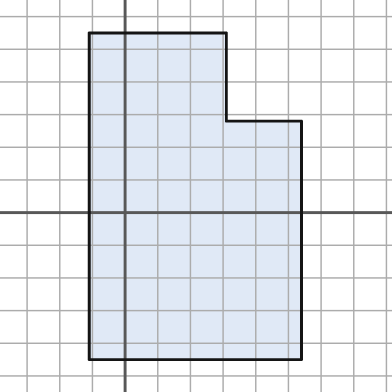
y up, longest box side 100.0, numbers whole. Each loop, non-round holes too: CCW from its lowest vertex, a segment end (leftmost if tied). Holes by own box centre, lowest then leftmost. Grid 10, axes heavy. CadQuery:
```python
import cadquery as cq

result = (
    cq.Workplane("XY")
    .moveTo(-11.0, -45.0)
    .lineTo(54.0, -45.0)
    .lineTo(54.0, 28.0)
    .lineTo(31.0, 28.0)
    .lineTo(31.0, 55.0)
    .lineTo(-11.0, 55.0)
    .close()
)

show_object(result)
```